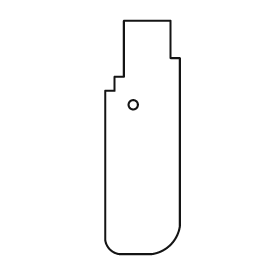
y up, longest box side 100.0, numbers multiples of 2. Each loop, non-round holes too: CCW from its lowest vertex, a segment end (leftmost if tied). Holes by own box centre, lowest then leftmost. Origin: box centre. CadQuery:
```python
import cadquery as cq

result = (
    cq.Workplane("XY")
    .moveTo(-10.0, -50.0)
    .lineTo(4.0, -50.0)
    .threePointArc((12.0, -46.0), (16.0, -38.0))
    .lineTo(16.0, 34.0)
    .lineTo(12.0, 34.0)
    .lineTo(12.0, 50.0)
    .lineTo(-8.0, 50.0)
    .lineTo(-8.0, 26.0)
    .lineTo(-12.0, 26.0)
    .lineTo(-12.0, 20.0)
    .lineTo(-16.0, 20.0)
    .lineTo(-16.0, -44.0)
    .threePointArc((-14.0, -48.0), (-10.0, -50.0))
    .close()
    .moveTo(-4.0, 14.0)
    .circle(2.0)
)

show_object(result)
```